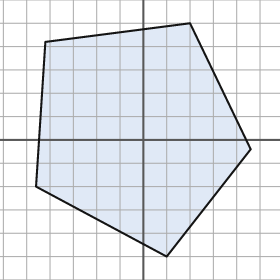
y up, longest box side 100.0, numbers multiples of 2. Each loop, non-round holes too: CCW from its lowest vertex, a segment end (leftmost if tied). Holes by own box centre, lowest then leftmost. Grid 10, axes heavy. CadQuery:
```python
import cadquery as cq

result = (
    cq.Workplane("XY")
    .moveTo(10.0, -50.0)
    .lineTo(46.0, -4.0)
    .lineTo(20.0, 50.0)
    .lineTo(-42.0, 42.0)
    .lineTo(-46.0, -20.0)
    .close()
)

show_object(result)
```